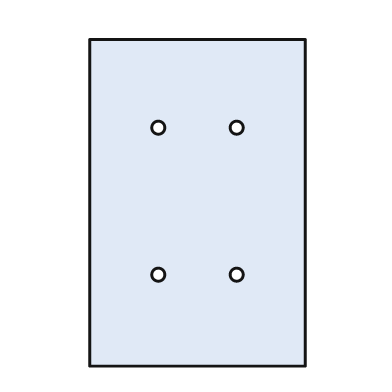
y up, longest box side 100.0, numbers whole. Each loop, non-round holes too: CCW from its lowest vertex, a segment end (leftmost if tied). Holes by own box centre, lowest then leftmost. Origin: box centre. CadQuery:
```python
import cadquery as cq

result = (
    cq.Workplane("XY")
    .moveTo(-33.0, -50.0)
    .lineTo(33.0, -50.0)
    .lineTo(33.0, 50.0)
    .lineTo(-33.0, 50.0)
    .close()
    .moveTo(-12.0, -22.0)
    .circle(2.0)
    .moveTo(12.0, -22.0)
    .circle(2.0)
    .moveTo(-12.0, 23.0)
    .circle(2.0)
    .moveTo(12.0, 23.0)
    .circle(2.0)
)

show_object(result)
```